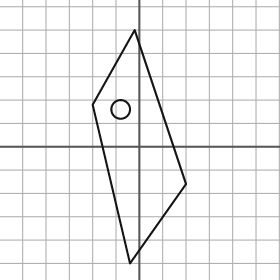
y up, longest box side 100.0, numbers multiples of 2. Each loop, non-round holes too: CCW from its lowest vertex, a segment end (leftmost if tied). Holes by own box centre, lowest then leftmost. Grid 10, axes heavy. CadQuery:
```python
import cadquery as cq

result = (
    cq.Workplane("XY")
    .moveTo(-4.0, -50.0)
    .lineTo(20.0, -16.0)
    .lineTo(-2.0, 50.0)
    .lineTo(-20.0, 18.0)
    .close()
    .moveTo(-8.0, 16.0)
    .circle(4.0)
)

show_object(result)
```